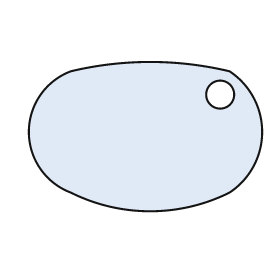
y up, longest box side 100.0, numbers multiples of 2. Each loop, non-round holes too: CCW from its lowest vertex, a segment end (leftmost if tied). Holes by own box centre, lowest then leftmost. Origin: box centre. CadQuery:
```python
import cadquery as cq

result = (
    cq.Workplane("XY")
    .moveTo(-32.0, -24.0)
    .threePointArc((2.0, -32.0), (36.0, -24.0))
    .threePointArc((50.0, 2.0), (36.0, 28.0))
    .threePointArc((2.0, 32.0), (-32.0, 28.0))
    .threePointArc((-50.0, 2.0), (-32.0, -24.0))
    .close()
    .moveTo(32.0, 18.0)
    .circle(6.0)
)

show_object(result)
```